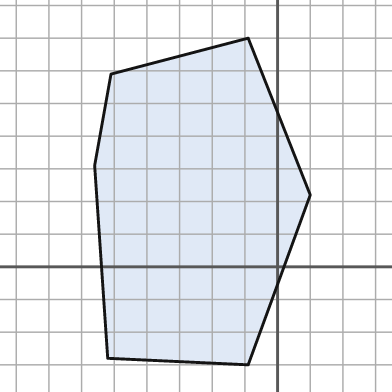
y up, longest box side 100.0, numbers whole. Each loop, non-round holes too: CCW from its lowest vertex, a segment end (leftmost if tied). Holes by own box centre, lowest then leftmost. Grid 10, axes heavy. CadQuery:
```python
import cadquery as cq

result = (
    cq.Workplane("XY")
    .moveTo(-9.0, -30.0)
    .lineTo(10.0, 22.0)
    .lineTo(-9.0, 70.0)
    .lineTo(-51.0, 59.0)
    .lineTo(-56.0, 31.0)
    .lineTo(-52.0, -28.0)
    .close()
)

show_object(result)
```